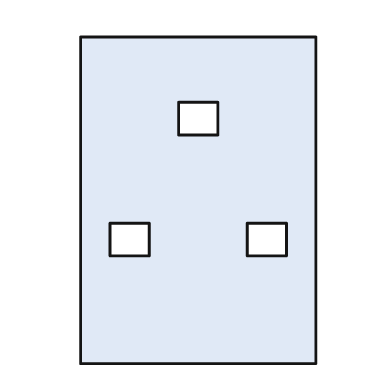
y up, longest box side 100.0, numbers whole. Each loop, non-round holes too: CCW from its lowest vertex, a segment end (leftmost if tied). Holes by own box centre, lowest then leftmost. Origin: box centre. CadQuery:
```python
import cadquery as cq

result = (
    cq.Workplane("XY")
    .moveTo(-36.0, -50.0)
    .lineTo(36.0, -50.0)
    .lineTo(36.0, 50.0)
    .lineTo(-36.0, 50.0)
    .close()
    .moveTo(-27.0, -17.0)
    .lineTo(-15.0, -17.0)
    .lineTo(-15.0, -7.0)
    .lineTo(-27.0, -7.0)
    .close()
    .moveTo(15.0, -17.0)
    .lineTo(27.0, -17.0)
    .lineTo(27.0, -7.0)
    .lineTo(15.0, -7.0)
    .close()
    .moveTo(-6.0, 20.0)
    .lineTo(6.0, 20.0)
    .lineTo(6.0, 30.0)
    .lineTo(-6.0, 30.0)
    .close()
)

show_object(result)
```